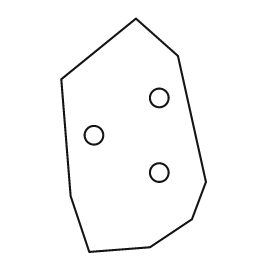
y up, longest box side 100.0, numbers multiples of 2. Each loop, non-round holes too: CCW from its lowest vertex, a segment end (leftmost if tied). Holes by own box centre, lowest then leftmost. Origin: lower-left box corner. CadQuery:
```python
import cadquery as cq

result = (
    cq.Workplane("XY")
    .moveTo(12.0, 0.0)
    .lineTo(38.0, 2.0)
    .lineTo(56.0, 14.0)
    .lineTo(62.0, 30.0)
    .lineTo(50.0, 84.0)
    .lineTo(32.0, 100.0)
    .lineTo(0.0, 74.0)
    .lineTo(4.0, 24.0)
    .close()
    .moveTo(42.0, 34.0)
    .circle(4.0)
    .moveTo(14.0, 50.0)
    .circle(4.0)
    .moveTo(42.0, 66.0)
    .circle(4.0)
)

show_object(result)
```